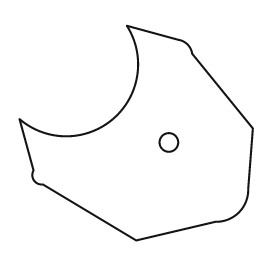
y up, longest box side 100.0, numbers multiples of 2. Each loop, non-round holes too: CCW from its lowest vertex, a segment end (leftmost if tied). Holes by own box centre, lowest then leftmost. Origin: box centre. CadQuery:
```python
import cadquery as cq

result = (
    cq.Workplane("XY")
    .moveTo(0.0, -46.0)
    .lineTo(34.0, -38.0)
    .threePointArc((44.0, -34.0), (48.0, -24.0))
    .lineTo(50.0, 2.0)
    .lineTo(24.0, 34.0)
    .threePointArc((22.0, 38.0), (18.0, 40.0))
    .lineTo(-4.0, 46.0)
    .threePointArc((-10.0, 6.0), (-50.0, 6.0))
    .lineTo(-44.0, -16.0)
    .threePointArc((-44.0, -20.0), (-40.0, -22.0))
    .close()
    .moveTo(14.0, -4.0)
    .circle(4.0)
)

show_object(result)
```